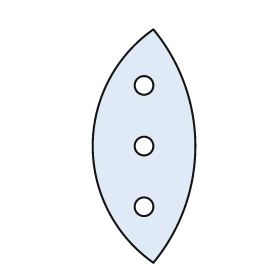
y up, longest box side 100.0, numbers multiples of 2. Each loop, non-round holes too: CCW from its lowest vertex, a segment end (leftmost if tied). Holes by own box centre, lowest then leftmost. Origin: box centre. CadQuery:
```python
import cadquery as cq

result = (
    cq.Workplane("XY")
    .moveTo(4.0, -50.0)
    .threePointArc((22.0, 0.0), (4.0, 50.0))
    .threePointArc((-22.0, 0.0), (4.0, -50.0))
    .close()
    .moveTo(0.0, -26.0)
    .circle(4.0)
    .moveTo(0.0, 0.0)
    .circle(4.0)
    .moveTo(0.0, 26.0)
    .circle(4.0)
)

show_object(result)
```